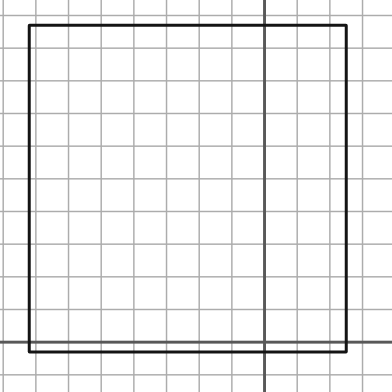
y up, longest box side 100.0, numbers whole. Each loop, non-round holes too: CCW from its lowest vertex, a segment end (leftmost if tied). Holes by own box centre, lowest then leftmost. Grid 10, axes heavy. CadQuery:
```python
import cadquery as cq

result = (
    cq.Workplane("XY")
    .moveTo(-72.0, -3.0)
    .lineTo(25.0, -3.0)
    .lineTo(25.0, 97.0)
    .lineTo(-72.0, 97.0)
    .close()
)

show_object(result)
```